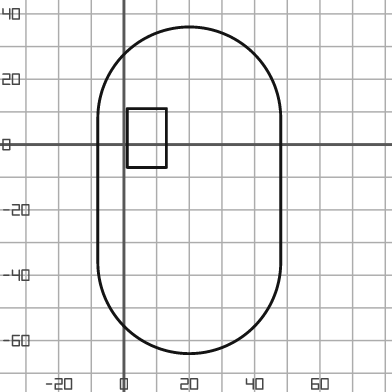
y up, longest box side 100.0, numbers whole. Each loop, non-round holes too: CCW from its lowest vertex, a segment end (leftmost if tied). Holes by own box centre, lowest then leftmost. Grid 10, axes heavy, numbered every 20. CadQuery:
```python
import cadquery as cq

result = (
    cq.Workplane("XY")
    .moveTo(-8.0, -36.0)
    .threePointArc((20.0, -64.0), (48.0, -36.0))
    .lineTo(48.0, 8.0)
    .threePointArc((20.0, 36.0), (-8.0, 8.0))
    .close()
    .moveTo(1.0, -7.0)
    .lineTo(13.0, -7.0)
    .lineTo(13.0, 11.0)
    .lineTo(1.0, 11.0)
    .close()
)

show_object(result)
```